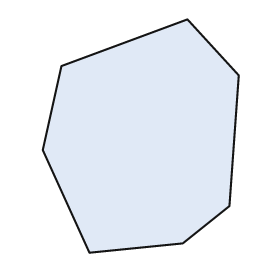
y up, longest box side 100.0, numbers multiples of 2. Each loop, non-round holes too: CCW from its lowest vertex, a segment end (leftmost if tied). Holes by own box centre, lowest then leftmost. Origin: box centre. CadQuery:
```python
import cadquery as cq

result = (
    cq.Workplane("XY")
    .moveTo(-22.0, -50.0)
    .lineTo(18.0, -46.0)
    .lineTo(38.0, -30.0)
    .lineTo(42.0, 26.0)
    .lineTo(20.0, 50.0)
    .lineTo(-34.0, 30.0)
    .lineTo(-42.0, -6.0)
    .close()
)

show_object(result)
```